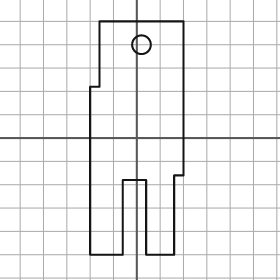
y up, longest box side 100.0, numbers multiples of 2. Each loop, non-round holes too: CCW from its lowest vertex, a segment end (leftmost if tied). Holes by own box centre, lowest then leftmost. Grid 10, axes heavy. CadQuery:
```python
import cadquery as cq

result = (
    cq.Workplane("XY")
    .moveTo(-20.0, -50.0)
    .lineTo(-6.0, -50.0)
    .lineTo(-6.0, -18.0)
    .lineTo(4.0, -18.0)
    .lineTo(4.0, -50.0)
    .lineTo(16.0, -50.0)
    .lineTo(16.0, -16.0)
    .lineTo(20.0, -16.0)
    .lineTo(20.0, 50.0)
    .lineTo(-16.0, 50.0)
    .lineTo(-16.0, 22.0)
    .lineTo(-20.0, 22.0)
    .close()
    .moveTo(2.0, 40.0)
    .circle(4.0)
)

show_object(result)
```